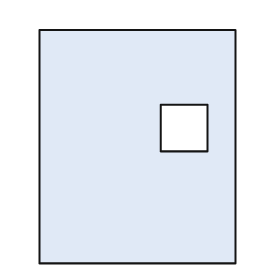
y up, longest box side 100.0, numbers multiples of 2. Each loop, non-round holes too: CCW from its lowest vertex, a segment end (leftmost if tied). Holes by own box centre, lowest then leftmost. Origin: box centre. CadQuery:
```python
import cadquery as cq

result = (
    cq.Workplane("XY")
    .moveTo(-42.0, -50.0)
    .lineTo(42.0, -50.0)
    .lineTo(42.0, 50.0)
    .lineTo(-42.0, 50.0)
    .close()
    .moveTo(10.0, -2.0)
    .lineTo(30.0, -2.0)
    .lineTo(30.0, 18.0)
    .lineTo(10.0, 18.0)
    .close()
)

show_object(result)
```